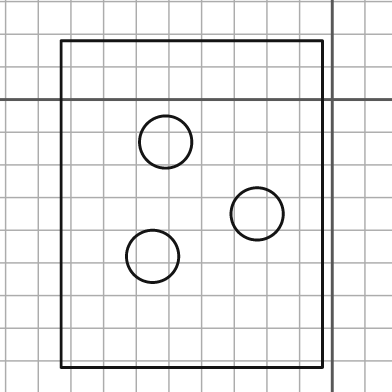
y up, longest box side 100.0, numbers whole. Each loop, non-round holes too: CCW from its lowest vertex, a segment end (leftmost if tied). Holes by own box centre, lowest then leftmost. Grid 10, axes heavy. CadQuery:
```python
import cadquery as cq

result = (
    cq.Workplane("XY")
    .moveTo(-83.0, -82.0)
    .lineTo(-3.0, -82.0)
    .lineTo(-3.0, 18.0)
    .lineTo(-83.0, 18.0)
    .close()
    .moveTo(-55.0, -48.0)
    .circle(8.0)
    .moveTo(-23.0, -35.0)
    .circle(8.0)
    .moveTo(-51.0, -13.0)
    .circle(8.0)
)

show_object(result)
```